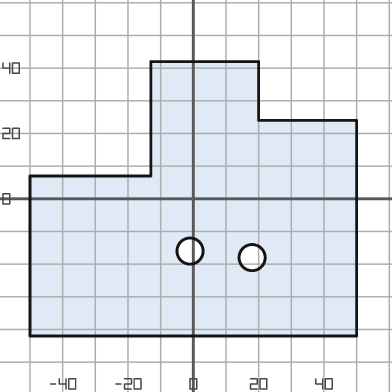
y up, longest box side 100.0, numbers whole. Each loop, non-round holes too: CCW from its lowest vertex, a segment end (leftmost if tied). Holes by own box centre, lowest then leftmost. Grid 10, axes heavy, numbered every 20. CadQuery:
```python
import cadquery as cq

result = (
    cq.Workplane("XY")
    .moveTo(-50.0, -42.0)
    .lineTo(50.0, -42.0)
    .lineTo(50.0, 24.0)
    .lineTo(20.0, 24.0)
    .lineTo(20.0, 42.0)
    .lineTo(-13.0, 42.0)
    .lineTo(-13.0, 7.0)
    .lineTo(-50.0, 7.0)
    .close()
    .moveTo(18.0, -18.0)
    .circle(4.0)
    .moveTo(-1.0, -16.0)
    .circle(4.0)
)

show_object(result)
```